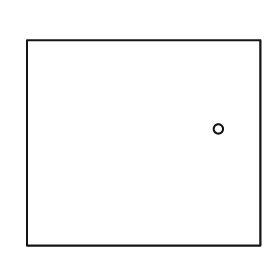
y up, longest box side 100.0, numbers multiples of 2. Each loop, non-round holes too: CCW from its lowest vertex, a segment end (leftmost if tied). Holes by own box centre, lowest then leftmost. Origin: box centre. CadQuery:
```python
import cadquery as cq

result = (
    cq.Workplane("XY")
    .moveTo(-50.0, -44.0)
    .lineTo(50.0, -44.0)
    .lineTo(50.0, 44.0)
    .lineTo(-50.0, 44.0)
    .close()
    .moveTo(32.0, 6.0)
    .circle(2.0)
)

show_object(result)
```